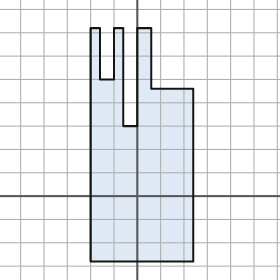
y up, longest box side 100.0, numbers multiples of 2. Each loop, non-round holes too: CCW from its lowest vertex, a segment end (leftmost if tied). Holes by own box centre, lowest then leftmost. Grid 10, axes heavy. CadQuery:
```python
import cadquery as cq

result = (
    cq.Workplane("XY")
    .moveTo(-20.0, -28.0)
    .lineTo(24.0, -28.0)
    .lineTo(24.0, 46.0)
    .lineTo(6.0, 46.0)
    .lineTo(6.0, 72.0)
    .lineTo(0.0, 72.0)
    .lineTo(0.0, 30.0)
    .lineTo(-6.0, 30.0)
    .lineTo(-6.0, 72.0)
    .lineTo(-10.0, 72.0)
    .lineTo(-10.0, 50.0)
    .lineTo(-16.0, 50.0)
    .lineTo(-16.0, 72.0)
    .lineTo(-20.0, 72.0)
    .close()
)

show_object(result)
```